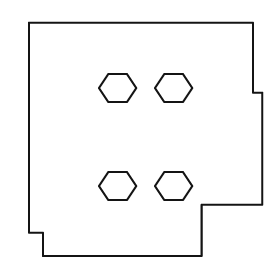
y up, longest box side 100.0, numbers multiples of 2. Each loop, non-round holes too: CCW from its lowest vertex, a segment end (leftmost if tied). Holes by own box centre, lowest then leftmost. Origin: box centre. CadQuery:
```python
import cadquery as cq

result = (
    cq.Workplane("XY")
    .moveTo(-44.0, -50.0)
    .lineTo(24.0, -50.0)
    .lineTo(24.0, -28.0)
    .lineTo(50.0, -28.0)
    .lineTo(50.0, 20.0)
    .lineTo(46.0, 20.0)
    .lineTo(46.0, 50.0)
    .lineTo(-50.0, 50.0)
    .lineTo(-50.0, -40.0)
    .lineTo(-44.0, -40.0)
    .close()
    .moveTo(-16.0, -26.0)
    .lineTo(-8.0, -26.0)
    .lineTo(-4.0, -20.0)
    .lineTo(-8.0, -14.0)
    .lineTo(-16.0, -14.0)
    .lineTo(-20.0, -20.0)
    .close()
    .moveTo(8.0, -26.0)
    .lineTo(16.0, -26.0)
    .lineTo(20.0, -20.0)
    .lineTo(16.0, -14.0)
    .lineTo(8.0, -14.0)
    .lineTo(4.0, -20.0)
    .close()
    .moveTo(-16.0, 16.0)
    .lineTo(-8.0, 16.0)
    .lineTo(-4.0, 22.0)
    .lineTo(-8.0, 28.0)
    .lineTo(-16.0, 28.0)
    .lineTo(-20.0, 22.0)
    .close()
    .moveTo(8.0, 16.0)
    .lineTo(16.0, 16.0)
    .lineTo(20.0, 22.0)
    .lineTo(16.0, 28.0)
    .lineTo(8.0, 28.0)
    .lineTo(4.0, 22.0)
    .close()
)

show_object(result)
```